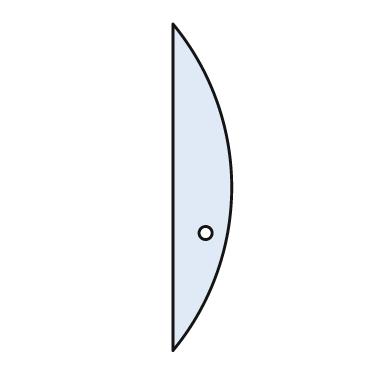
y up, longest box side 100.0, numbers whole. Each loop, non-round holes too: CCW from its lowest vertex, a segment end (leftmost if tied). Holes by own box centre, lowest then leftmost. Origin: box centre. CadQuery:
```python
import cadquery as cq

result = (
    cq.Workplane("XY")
    .moveTo(-9.0, -50.0)
    .threePointArc((9.0, 0.0), (-9.0, 50.0))
    .close()
    .moveTo(1.0, -14.0)
    .circle(2.0)
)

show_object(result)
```